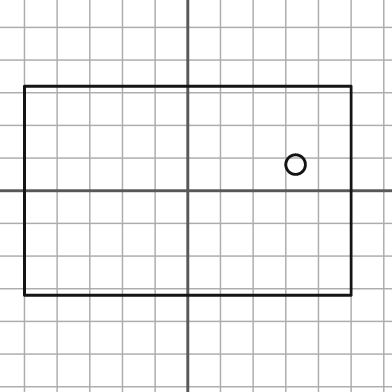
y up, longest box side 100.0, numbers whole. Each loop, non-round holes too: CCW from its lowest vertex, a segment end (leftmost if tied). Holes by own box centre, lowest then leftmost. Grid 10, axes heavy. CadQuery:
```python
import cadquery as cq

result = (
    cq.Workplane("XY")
    .moveTo(-50.0, -32.0)
    .lineTo(50.0, -32.0)
    .lineTo(50.0, 32.0)
    .lineTo(-50.0, 32.0)
    .close()
    .moveTo(33.0, 8.0)
    .circle(3.0)
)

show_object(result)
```